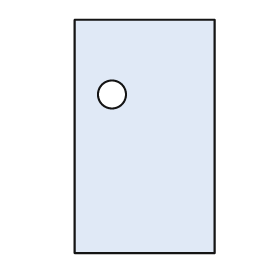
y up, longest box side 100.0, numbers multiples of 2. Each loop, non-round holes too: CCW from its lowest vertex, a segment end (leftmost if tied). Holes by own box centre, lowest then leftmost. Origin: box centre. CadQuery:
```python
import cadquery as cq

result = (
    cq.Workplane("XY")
    .moveTo(-30.0, -50.0)
    .lineTo(30.0, -50.0)
    .lineTo(30.0, 50.0)
    .lineTo(-30.0, 50.0)
    .close()
    .moveTo(-14.0, 18.0)
    .circle(6.0)
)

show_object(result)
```